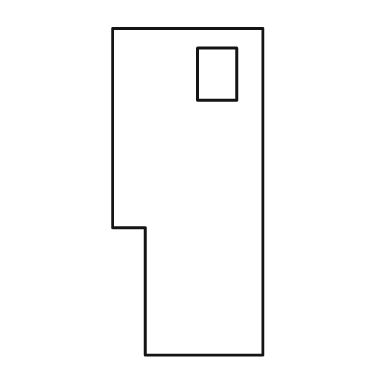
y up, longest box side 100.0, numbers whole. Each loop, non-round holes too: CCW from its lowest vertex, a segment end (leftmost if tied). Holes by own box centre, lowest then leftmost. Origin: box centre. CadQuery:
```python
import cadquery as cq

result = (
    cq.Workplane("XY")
    .moveTo(-13.0, -50.0)
    .lineTo(23.0, -50.0)
    .lineTo(23.0, 50.0)
    .lineTo(-23.0, 50.0)
    .lineTo(-23.0, -11.0)
    .lineTo(-13.0, -11.0)
    .close()
    .moveTo(3.0, 28.0)
    .lineTo(15.0, 28.0)
    .lineTo(15.0, 44.0)
    .lineTo(3.0, 44.0)
    .close()
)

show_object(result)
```